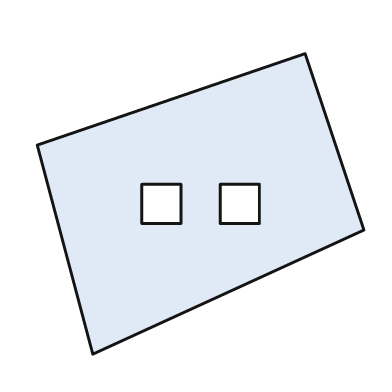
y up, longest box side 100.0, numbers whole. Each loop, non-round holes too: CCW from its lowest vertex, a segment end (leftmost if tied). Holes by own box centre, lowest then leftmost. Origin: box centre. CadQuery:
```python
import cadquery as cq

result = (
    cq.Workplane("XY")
    .moveTo(-33.0, -46.0)
    .lineTo(50.0, -8.0)
    .lineTo(32.0, 46.0)
    .lineTo(-50.0, 18.0)
    .close()
    .moveTo(-18.0, -6.0)
    .lineTo(-6.0, -6.0)
    .lineTo(-6.0, 6.0)
    .lineTo(-18.0, 6.0)
    .close()
    .moveTo(6.0, -6.0)
    .lineTo(18.0, -6.0)
    .lineTo(18.0, 6.0)
    .lineTo(6.0, 6.0)
    .close()
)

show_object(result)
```